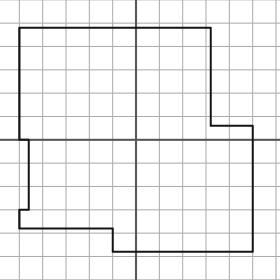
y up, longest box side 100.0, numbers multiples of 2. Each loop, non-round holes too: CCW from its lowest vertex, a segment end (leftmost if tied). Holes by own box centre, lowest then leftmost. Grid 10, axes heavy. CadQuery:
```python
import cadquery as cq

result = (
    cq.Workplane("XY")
    .moveTo(-10.0, -48.0)
    .lineTo(50.0, -48.0)
    .lineTo(50.0, 6.0)
    .lineTo(32.0, 6.0)
    .lineTo(32.0, 48.0)
    .lineTo(-50.0, 48.0)
    .lineTo(-50.0, 0.0)
    .lineTo(-46.0, 0.0)
    .lineTo(-46.0, -30.0)
    .lineTo(-50.0, -30.0)
    .lineTo(-50.0, -38.0)
    .lineTo(-10.0, -38.0)
    .close()
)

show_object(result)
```